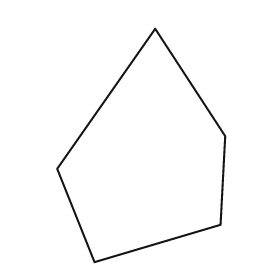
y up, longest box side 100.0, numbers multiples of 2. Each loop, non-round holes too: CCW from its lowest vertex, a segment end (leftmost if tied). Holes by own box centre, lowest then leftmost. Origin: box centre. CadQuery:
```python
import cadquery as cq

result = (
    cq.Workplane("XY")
    .moveTo(-20.0, -50.0)
    .lineTo(34.0, -34.0)
    .lineTo(36.0, 4.0)
    .lineTo(6.0, 50.0)
    .lineTo(-36.0, -10.0)
    .close()
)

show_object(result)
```